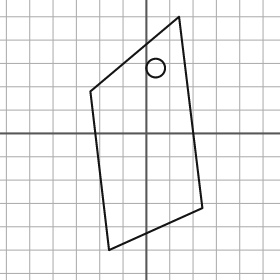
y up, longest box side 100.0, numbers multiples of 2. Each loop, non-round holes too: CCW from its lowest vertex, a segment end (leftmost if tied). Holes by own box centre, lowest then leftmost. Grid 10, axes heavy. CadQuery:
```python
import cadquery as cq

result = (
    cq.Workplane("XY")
    .moveTo(-16.0, -50.0)
    .lineTo(24.0, -32.0)
    .lineTo(14.0, 50.0)
    .lineTo(-24.0, 18.0)
    .close()
    .moveTo(4.0, 28.0)
    .circle(4.0)
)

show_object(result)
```